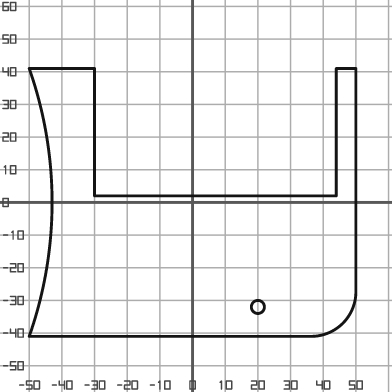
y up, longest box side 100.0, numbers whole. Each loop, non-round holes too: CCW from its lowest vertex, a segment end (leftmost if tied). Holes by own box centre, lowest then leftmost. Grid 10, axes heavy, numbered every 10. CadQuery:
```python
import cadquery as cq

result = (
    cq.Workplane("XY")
    .moveTo(-50.0, -41.0)
    .lineTo(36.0, -41.0)
    .threePointArc((46.0, -37.0), (50.0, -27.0))
    .lineTo(50.0, 41.0)
    .lineTo(44.0, 41.0)
    .lineTo(44.0, 2.0)
    .lineTo(-30.0, 2.0)
    .lineTo(-30.0, 41.0)
    .lineTo(-50.0, 41.0)
    .threePointArc((-43.0, 0.0), (-50.0, -41.0))
    .close()
    .moveTo(20.0, -32.0)
    .circle(2.0)
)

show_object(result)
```